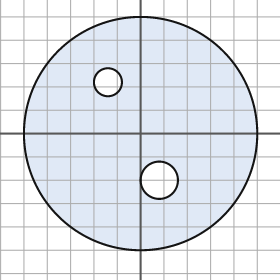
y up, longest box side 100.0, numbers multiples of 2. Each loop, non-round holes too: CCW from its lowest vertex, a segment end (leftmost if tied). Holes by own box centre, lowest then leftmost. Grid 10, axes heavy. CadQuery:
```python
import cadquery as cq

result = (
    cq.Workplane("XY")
    .moveTo(0.0, 0.0)
    .circle(50.0)
    .moveTo(8.0, -20.0)
    .circle(8.0)
    .moveTo(-14.0, 22.0)
    .circle(6.0)
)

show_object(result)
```